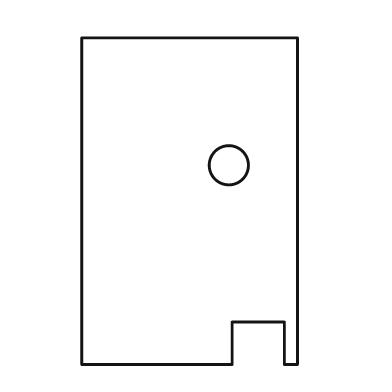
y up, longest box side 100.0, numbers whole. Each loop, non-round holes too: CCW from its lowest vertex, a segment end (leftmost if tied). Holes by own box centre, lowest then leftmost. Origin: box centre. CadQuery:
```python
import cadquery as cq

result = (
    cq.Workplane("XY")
    .moveTo(-33.0, -50.0)
    .lineTo(13.0, -50.0)
    .lineTo(13.0, -37.0)
    .lineTo(29.0, -37.0)
    .lineTo(29.0, -50.0)
    .lineTo(33.0, -50.0)
    .lineTo(33.0, 50.0)
    .lineTo(-33.0, 50.0)
    .close()
    .moveTo(12.0, 11.0)
    .circle(6.0)
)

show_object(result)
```